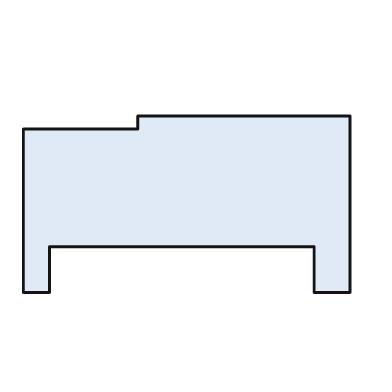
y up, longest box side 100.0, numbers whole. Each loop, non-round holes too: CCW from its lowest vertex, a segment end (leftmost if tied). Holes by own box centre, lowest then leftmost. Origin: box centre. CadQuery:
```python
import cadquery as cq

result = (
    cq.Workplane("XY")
    .moveTo(-50.0, -27.0)
    .lineTo(-42.0, -27.0)
    .lineTo(-42.0, -13.0)
    .lineTo(39.0, -13.0)
    .lineTo(39.0, -27.0)
    .lineTo(50.0, -27.0)
    .lineTo(50.0, 27.0)
    .lineTo(-15.0, 27.0)
    .lineTo(-15.0, 23.0)
    .lineTo(-50.0, 23.0)
    .close()
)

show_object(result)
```